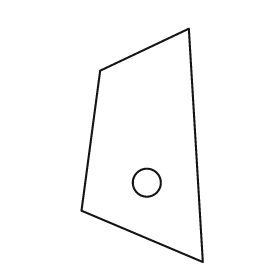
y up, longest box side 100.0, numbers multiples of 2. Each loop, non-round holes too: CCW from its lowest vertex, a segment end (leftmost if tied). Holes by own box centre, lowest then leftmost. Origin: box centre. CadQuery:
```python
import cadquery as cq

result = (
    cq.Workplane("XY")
    .moveTo(26.0, -50.0)
    .lineTo(20.0, 50.0)
    .lineTo(-18.0, 32.0)
    .lineTo(-26.0, -28.0)
    .close()
    .moveTo(2.0, -16.0)
    .circle(6.0)
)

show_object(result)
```